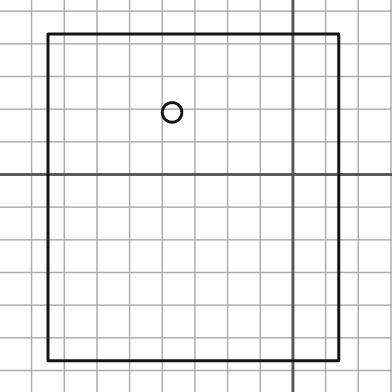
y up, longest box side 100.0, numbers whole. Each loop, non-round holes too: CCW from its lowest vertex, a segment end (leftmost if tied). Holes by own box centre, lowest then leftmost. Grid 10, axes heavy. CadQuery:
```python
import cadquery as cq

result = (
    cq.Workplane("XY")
    .moveTo(-75.0, -57.0)
    .lineTo(14.0, -57.0)
    .lineTo(14.0, 43.0)
    .lineTo(-75.0, 43.0)
    .close()
    .moveTo(-37.0, 19.0)
    .circle(3.0)
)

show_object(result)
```